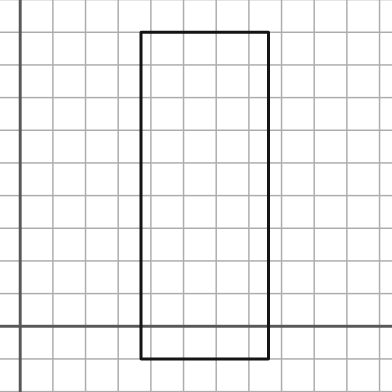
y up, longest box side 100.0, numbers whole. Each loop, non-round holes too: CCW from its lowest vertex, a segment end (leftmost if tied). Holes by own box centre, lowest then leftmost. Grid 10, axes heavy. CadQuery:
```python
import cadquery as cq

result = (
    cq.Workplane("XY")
    .moveTo(37.0, -10.0)
    .lineTo(76.0, -10.0)
    .lineTo(76.0, 90.0)
    .lineTo(37.0, 90.0)
    .close()
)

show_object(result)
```